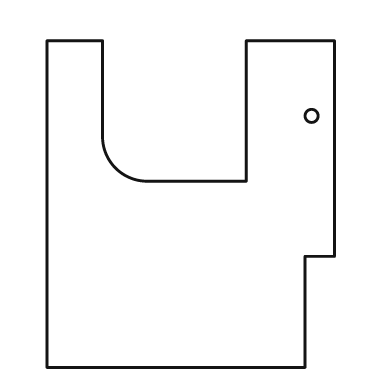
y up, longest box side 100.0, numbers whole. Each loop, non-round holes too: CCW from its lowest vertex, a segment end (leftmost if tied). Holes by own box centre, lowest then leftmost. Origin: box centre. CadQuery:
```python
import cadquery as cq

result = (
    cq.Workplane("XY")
    .moveTo(-44.0, -50.0)
    .lineTo(35.0, -50.0)
    .lineTo(35.0, -16.0)
    .lineTo(44.0, -16.0)
    .lineTo(44.0, 50.0)
    .lineTo(17.0, 50.0)
    .lineTo(17.0, 7.0)
    .lineTo(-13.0, 7.0)
    .threePointArc((-23.0, 11.0), (-27.0, 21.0))
    .lineTo(-27.0, 50.0)
    .lineTo(-44.0, 50.0)
    .close()
    .moveTo(37.0, 27.0)
    .circle(2.0)
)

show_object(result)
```